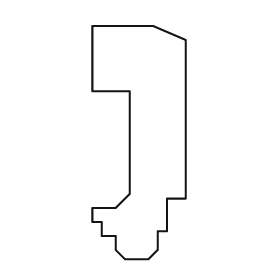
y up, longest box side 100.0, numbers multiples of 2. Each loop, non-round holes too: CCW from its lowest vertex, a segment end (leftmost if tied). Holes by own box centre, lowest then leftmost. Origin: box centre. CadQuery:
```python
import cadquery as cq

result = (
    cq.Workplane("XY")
    .moveTo(-6.0, -50.0)
    .lineTo(4.0, -50.0)
    .lineTo(8.0, -46.0)
    .lineTo(8.0, -38.0)
    .lineTo(12.0, -38.0)
    .lineTo(12.0, -24.0)
    .lineTo(20.0, -24.0)
    .lineTo(20.0, 44.0)
    .lineTo(6.0, 50.0)
    .lineTo(-20.0, 50.0)
    .lineTo(-20.0, 22.0)
    .lineTo(-4.0, 22.0)
    .lineTo(-4.0, -22.0)
    .lineTo(-10.0, -28.0)
    .lineTo(-20.0, -28.0)
    .lineTo(-20.0, -34.0)
    .lineTo(-16.0, -34.0)
    .lineTo(-16.0, -40.0)
    .lineTo(-10.0, -40.0)
    .lineTo(-10.0, -46.0)
    .close()
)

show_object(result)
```